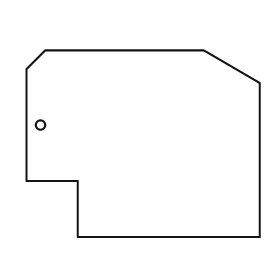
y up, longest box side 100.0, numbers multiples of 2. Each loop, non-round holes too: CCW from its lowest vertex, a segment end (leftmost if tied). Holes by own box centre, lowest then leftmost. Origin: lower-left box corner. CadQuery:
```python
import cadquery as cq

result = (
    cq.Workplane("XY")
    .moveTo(22.0, 0.0)
    .lineTo(100.0, 0.0)
    .lineTo(100.0, 66.0)
    .lineTo(76.0, 80.0)
    .lineTo(8.0, 80.0)
    .lineTo(0.0, 72.0)
    .lineTo(0.0, 24.0)
    .lineTo(22.0, 24.0)
    .close()
    .moveTo(6.0, 48.0)
    .circle(2.0)
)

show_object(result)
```